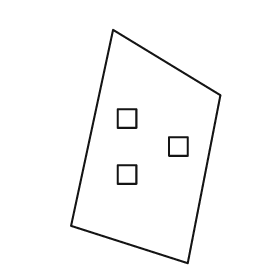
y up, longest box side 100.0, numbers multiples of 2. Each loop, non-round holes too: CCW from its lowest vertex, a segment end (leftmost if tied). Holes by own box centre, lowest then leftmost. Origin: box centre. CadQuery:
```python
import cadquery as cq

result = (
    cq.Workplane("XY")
    .moveTo(18.0, -50.0)
    .lineTo(32.0, 22.0)
    .lineTo(-14.0, 50.0)
    .lineTo(-32.0, -34.0)
    .close()
    .moveTo(-12.0, -16.0)
    .lineTo(-4.0, -16.0)
    .lineTo(-4.0, -8.0)
    .lineTo(-12.0, -8.0)
    .close()
    .moveTo(10.0, -4.0)
    .lineTo(18.0, -4.0)
    .lineTo(18.0, 4.0)
    .lineTo(10.0, 4.0)
    .close()
    .moveTo(-12.0, 8.0)
    .lineTo(-4.0, 8.0)
    .lineTo(-4.0, 16.0)
    .lineTo(-12.0, 16.0)
    .close()
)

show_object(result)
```